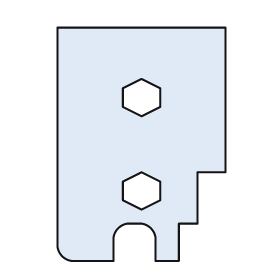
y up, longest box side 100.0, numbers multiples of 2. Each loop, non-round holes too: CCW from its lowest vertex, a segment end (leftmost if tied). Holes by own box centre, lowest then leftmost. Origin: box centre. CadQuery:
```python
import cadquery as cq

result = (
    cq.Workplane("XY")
    .moveTo(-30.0, -50.0)
    .lineTo(-12.0, -50.0)
    .lineTo(-12.0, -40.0)
    .threePointArc((-10.0, -36.0), (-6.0, -34.0))
    .lineTo(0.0, -34.0)
    .threePointArc((4.0, -36.0), (6.0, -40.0))
    .lineTo(6.0, -50.0)
    .lineTo(16.0, -50.0)
    .lineTo(16.0, -34.0)
    .lineTo(24.0, -34.0)
    .lineTo(24.0, -12.0)
    .lineTo(36.0, -12.0)
    .lineTo(36.0, 50.0)
    .lineTo(-36.0, 50.0)
    .lineTo(-36.0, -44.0)
    .threePointArc((-34.0, -48.0), (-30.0, -50.0))
    .close()
    .moveTo(0.0, -28.0)
    .lineTo(8.0, -24.0)
    .lineTo(8.0, -16.0)
    .lineTo(0.0, -12.0)
    .lineTo(-8.0, -16.0)
    .lineTo(-8.0, -24.0)
    .close()
    .moveTo(0.0, 12.0)
    .lineTo(8.0, 16.0)
    .lineTo(8.0, 24.0)
    .lineTo(0.0, 28.0)
    .lineTo(-8.0, 24.0)
    .lineTo(-8.0, 16.0)
    .close()
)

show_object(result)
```